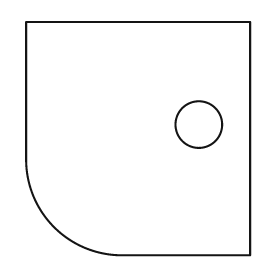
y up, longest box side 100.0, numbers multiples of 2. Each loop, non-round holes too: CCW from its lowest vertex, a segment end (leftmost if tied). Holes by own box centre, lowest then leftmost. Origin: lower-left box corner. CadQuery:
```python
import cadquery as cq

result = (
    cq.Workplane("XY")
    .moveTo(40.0, 0.0)
    .lineTo(96.0, 0.0)
    .lineTo(96.0, 100.0)
    .lineTo(0.0, 100.0)
    .lineTo(0.0, 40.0)
    .threePointArc((12.0, 12.0), (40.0, 0.0))
    .close()
    .moveTo(74.0, 56.0)
    .circle(10.0)
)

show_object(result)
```